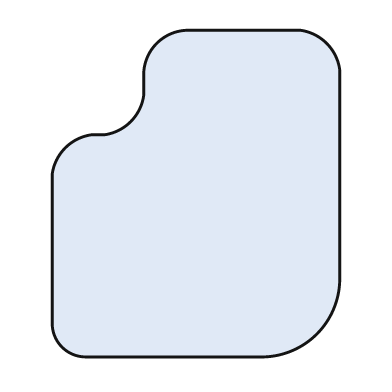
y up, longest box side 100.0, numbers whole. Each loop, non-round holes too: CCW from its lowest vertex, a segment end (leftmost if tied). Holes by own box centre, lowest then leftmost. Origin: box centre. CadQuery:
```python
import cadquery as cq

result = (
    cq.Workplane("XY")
    .moveTo(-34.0, -50.0)
    .lineTo(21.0, -50.0)
    .threePointArc((37.0, -43.0), (44.0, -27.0))
    .lineTo(44.0, 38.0)
    .threePointArc((40.0, 46.0), (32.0, 50.0))
    .lineTo(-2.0, 50.0)
    .threePointArc((-12.0, 46.0), (-16.0, 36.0))
    .lineTo(-16.0, 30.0)
    .threePointArc((-20.0, 22.0), (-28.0, 18.0))
    .lineTo(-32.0, 18.0)
    .threePointArc((-40.0, 14.0), (-44.0, 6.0))
    .lineTo(-44.0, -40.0)
    .threePointArc((-41.0, -47.0), (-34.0, -50.0))
    .close()
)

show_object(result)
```